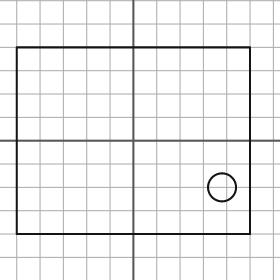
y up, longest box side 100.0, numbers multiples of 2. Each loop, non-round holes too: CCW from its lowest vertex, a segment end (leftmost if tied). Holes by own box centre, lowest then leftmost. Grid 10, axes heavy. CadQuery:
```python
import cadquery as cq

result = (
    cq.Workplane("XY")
    .moveTo(-50.0, -40.0)
    .lineTo(50.0, -40.0)
    .lineTo(50.0, 40.0)
    .lineTo(-50.0, 40.0)
    .close()
    .moveTo(38.0, -20.0)
    .circle(6.0)
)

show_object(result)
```